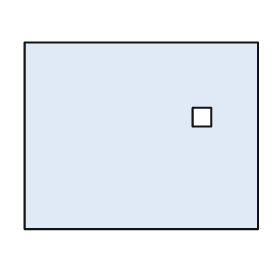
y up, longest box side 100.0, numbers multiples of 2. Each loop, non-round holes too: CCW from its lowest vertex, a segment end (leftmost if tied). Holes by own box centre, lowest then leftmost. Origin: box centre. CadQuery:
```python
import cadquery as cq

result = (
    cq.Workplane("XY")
    .moveTo(-50.0, -40.0)
    .lineTo(50.0, -40.0)
    .lineTo(50.0, 40.0)
    .lineTo(-50.0, 40.0)
    .close()
    .moveTo(22.0, 4.0)
    .lineTo(30.0, 4.0)
    .lineTo(30.0, 12.0)
    .lineTo(22.0, 12.0)
    .close()
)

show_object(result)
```